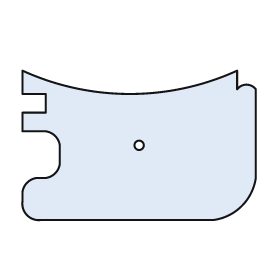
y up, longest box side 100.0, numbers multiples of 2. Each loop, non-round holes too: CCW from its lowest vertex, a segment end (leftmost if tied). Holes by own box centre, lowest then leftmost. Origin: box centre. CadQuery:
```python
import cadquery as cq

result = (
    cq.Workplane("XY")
    .moveTo(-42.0, -32.0)
    .lineTo(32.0, -32.0)
    .threePointArc((44.0, -26.0), (50.0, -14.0))
    .lineTo(50.0, 24.0)
    .threePointArc((46.0, 26.0), (42.0, 24.0))
    .lineTo(42.0, 32.0)
    .threePointArc((-4.0, 22.0), (-50.0, 32.0))
    .lineTo(-50.0, 22.0)
    .lineTo(-40.0, 22.0)
    .lineTo(-40.0, 14.0)
    .lineTo(-50.0, 14.0)
    .lineTo(-50.0, 6.0)
    .lineTo(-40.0, 6.0)
    .threePointArc((-36.0, 4.0), (-34.0, 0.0))
    .lineTo(-34.0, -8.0)
    .threePointArc((-36.0, -12.0), (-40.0, -14.0))
    .lineTo(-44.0, -14.0)
    .threePointArc((-48.0, -16.0), (-50.0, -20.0))
    .lineTo(-50.0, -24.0)
    .threePointArc((-48.0, -30.0), (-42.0, -32.0))
    .close()
    .moveTo(0.0, 0.0)
    .circle(2.0)
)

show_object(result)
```